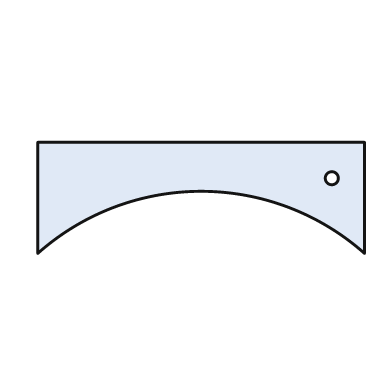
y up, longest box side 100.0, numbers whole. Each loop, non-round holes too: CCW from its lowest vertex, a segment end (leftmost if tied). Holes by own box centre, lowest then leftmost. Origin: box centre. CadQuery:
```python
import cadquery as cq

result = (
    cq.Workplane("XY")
    .moveTo(-50.0, -17.0)
    .threePointArc((0.0, 2.0), (50.0, -17.0))
    .lineTo(50.0, 17.0)
    .lineTo(-50.0, 17.0)
    .close()
    .moveTo(40.0, 6.0)
    .circle(2.0)
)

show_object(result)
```